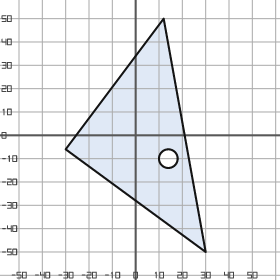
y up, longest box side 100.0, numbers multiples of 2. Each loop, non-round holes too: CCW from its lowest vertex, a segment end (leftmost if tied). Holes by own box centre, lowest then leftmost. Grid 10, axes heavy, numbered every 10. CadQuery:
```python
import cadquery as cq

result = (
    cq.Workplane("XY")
    .moveTo(30.0, -50.0)
    .lineTo(12.0, 50.0)
    .lineTo(-30.0, -6.0)
    .close()
    .moveTo(14.0, -10.0)
    .circle(4.0)
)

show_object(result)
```